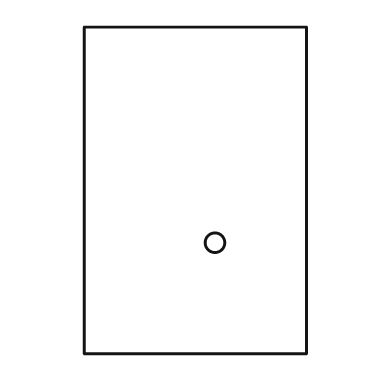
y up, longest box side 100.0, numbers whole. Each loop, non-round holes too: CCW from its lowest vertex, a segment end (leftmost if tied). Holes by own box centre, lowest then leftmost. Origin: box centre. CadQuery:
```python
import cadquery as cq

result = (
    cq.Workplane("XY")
    .moveTo(-34.0, -50.0)
    .lineTo(34.0, -50.0)
    .lineTo(34.0, 50.0)
    .lineTo(-34.0, 50.0)
    .close()
    .moveTo(6.0, -16.0)
    .circle(3.0)
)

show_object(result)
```